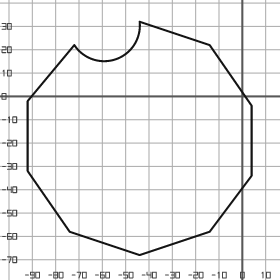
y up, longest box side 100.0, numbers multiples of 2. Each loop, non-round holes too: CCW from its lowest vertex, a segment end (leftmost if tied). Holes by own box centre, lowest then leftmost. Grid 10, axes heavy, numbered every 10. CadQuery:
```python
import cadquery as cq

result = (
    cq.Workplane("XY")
    .moveTo(-44.0, -68.0)
    .lineTo(-14.0, -58.0)
    .lineTo(4.0, -34.0)
    .lineTo(4.0, -4.0)
    .lineTo(-14.0, 22.0)
    .lineTo(-44.0, 32.0)
    .threePointArc((-54.0, 16.0), (-72.0, 22.0))
    .lineTo(-92.0, -2.0)
    .lineTo(-92.0, -32.0)
    .lineTo(-74.0, -58.0)
    .close()
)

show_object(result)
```